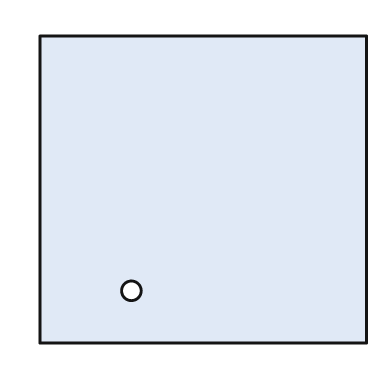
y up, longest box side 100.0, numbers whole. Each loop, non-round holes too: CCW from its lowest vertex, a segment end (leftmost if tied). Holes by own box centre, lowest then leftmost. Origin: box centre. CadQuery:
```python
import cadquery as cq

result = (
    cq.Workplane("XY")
    .moveTo(-50.0, -47.0)
    .lineTo(50.0, -47.0)
    .lineTo(50.0, 47.0)
    .lineTo(-50.0, 47.0)
    .close()
    .moveTo(-22.0, -31.0)
    .circle(3.0)
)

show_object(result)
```